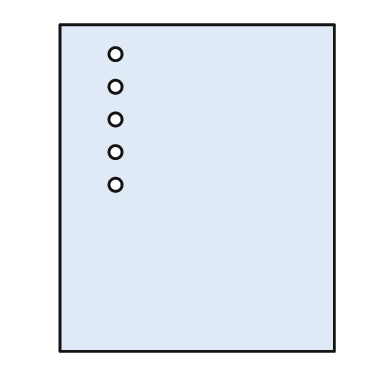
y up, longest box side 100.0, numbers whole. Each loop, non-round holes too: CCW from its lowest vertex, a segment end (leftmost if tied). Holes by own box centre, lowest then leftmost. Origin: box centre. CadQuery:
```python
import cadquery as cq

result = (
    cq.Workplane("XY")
    .moveTo(-42.0, -50.0)
    .lineTo(42.0, -50.0)
    .lineTo(42.0, 50.0)
    .lineTo(-42.0, 50.0)
    .close()
    .moveTo(-25.0, 1.0)
    .circle(2.0)
    .moveTo(-25.0, 11.0)
    .circle(2.0)
    .moveTo(-25.0, 21.0)
    .circle(2.0)
    .moveTo(-25.0, 31.0)
    .circle(2.0)
    .moveTo(-25.0, 41.0)
    .circle(2.0)
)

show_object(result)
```